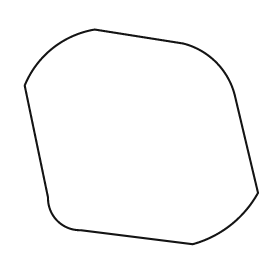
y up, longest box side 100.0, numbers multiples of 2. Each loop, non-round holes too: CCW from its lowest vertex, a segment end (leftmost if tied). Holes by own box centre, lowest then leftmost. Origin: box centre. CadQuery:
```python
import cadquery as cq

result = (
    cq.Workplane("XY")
    .moveTo(22.0, -46.0)
    .threePointArc((38.0, -38.0), (50.0, -24.0))
    .lineTo(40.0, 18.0)
    .threePointArc((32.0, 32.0), (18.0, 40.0))
    .lineTo(-20.0, 46.0)
    .threePointArc((-38.0, 38.0), (-50.0, 22.0))
    .lineTo(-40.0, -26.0)
    .threePointArc((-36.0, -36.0), (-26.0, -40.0))
    .close()
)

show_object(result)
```